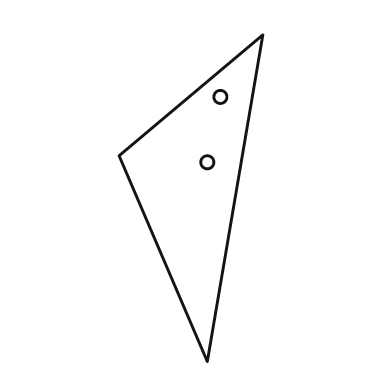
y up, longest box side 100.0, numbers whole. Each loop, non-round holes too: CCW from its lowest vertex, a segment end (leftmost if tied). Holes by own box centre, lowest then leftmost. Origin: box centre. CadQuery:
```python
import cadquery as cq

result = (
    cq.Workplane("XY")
    .moveTo(5.0, -50.0)
    .lineTo(22.0, 50.0)
    .lineTo(-22.0, 13.0)
    .close()
    .moveTo(5.0, 11.0)
    .circle(2.0)
    .moveTo(9.0, 31.0)
    .circle(2.0)
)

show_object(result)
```